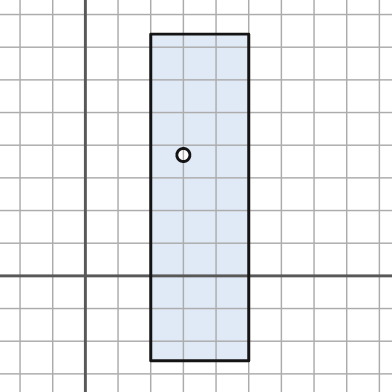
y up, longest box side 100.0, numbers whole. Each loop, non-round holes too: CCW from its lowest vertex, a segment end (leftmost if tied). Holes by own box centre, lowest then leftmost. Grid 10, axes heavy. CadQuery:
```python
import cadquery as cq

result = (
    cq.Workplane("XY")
    .moveTo(20.0, -26.0)
    .lineTo(50.0, -26.0)
    .lineTo(50.0, 74.0)
    .lineTo(20.0, 74.0)
    .close()
    .moveTo(30.0, 37.0)
    .circle(2.0)
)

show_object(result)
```